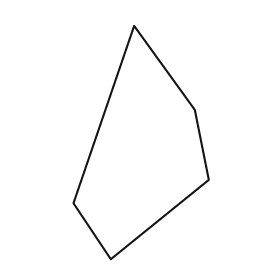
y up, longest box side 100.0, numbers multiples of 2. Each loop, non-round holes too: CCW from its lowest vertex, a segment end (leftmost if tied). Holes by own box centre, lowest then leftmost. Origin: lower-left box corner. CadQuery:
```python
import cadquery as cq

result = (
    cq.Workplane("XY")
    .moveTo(16.0, 0.0)
    .lineTo(58.0, 34.0)
    .lineTo(52.0, 64.0)
    .lineTo(26.0, 100.0)
    .lineTo(0.0, 24.0)
    .close()
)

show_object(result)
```